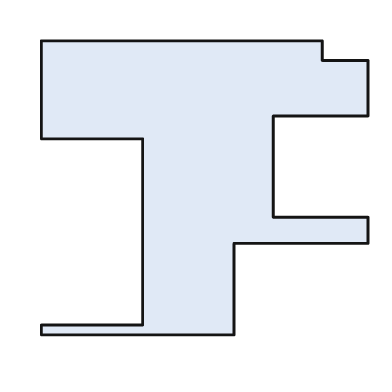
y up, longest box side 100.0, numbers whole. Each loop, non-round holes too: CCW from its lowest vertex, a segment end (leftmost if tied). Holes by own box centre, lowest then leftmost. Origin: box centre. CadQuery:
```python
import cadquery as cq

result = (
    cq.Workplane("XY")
    .moveTo(-50.0, -45.0)
    .lineTo(9.0, -45.0)
    .lineTo(9.0, -17.0)
    .lineTo(50.0, -17.0)
    .lineTo(50.0, -9.0)
    .lineTo(21.0, -9.0)
    .lineTo(21.0, 22.0)
    .lineTo(50.0, 22.0)
    .lineTo(50.0, 39.0)
    .lineTo(36.0, 39.0)
    .lineTo(36.0, 45.0)
    .lineTo(-50.0, 45.0)
    .lineTo(-50.0, 15.0)
    .lineTo(-19.0, 15.0)
    .lineTo(-19.0, -42.0)
    .lineTo(-50.0, -42.0)
    .close()
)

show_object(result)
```